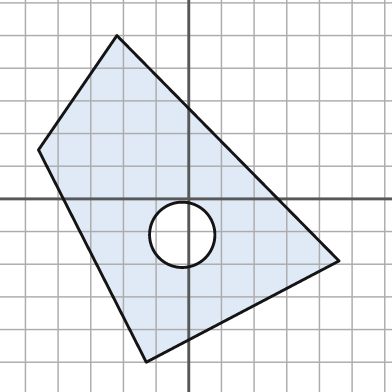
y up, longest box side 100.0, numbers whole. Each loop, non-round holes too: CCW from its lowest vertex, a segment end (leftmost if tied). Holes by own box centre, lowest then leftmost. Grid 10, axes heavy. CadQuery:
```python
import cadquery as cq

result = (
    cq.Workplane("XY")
    .moveTo(-13.0, -50.0)
    .lineTo(46.0, -19.0)
    .lineTo(-22.0, 50.0)
    .lineTo(-46.0, 15.0)
    .close()
    .moveTo(-2.0, -11.0)
    .circle(10.0)
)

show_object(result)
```